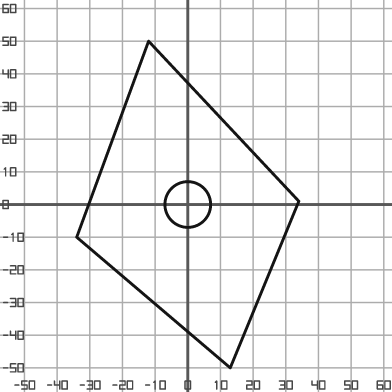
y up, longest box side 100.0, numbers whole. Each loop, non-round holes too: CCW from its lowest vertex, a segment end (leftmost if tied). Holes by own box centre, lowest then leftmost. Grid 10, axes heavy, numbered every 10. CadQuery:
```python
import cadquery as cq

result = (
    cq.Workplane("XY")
    .moveTo(13.0, -50.0)
    .lineTo(34.0, 1.0)
    .lineTo(-12.0, 50.0)
    .lineTo(-34.0, -10.0)
    .close()
    .moveTo(0.0, 0.0)
    .circle(7.0)
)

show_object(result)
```